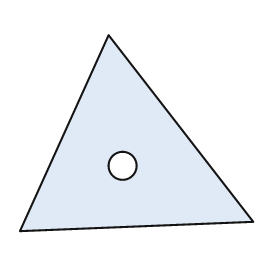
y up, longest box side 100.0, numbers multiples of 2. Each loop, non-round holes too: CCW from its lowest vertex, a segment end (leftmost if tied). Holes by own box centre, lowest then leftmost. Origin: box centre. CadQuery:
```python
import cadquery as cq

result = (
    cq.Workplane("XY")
    .moveTo(-50.0, -42.0)
    .lineTo(50.0, -38.0)
    .lineTo(-12.0, 42.0)
    .close()
    .moveTo(-6.0, -14.0)
    .circle(6.0)
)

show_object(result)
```